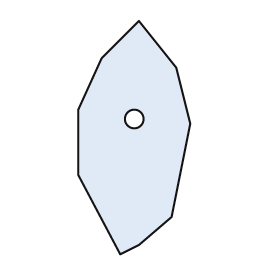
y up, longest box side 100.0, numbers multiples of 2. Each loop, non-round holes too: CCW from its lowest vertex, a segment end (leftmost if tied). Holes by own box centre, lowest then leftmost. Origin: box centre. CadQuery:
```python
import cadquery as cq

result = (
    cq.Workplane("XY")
    .moveTo(-6.0, -50.0)
    .lineTo(2.0, -46.0)
    .lineTo(16.0, -34.0)
    .lineTo(24.0, 6.0)
    .lineTo(18.0, 30.0)
    .lineTo(2.0, 50.0)
    .lineTo(-14.0, 34.0)
    .lineTo(-24.0, 12.0)
    .lineTo(-24.0, -16.0)
    .close()
    .moveTo(0.0, 8.0)
    .circle(4.0)
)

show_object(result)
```